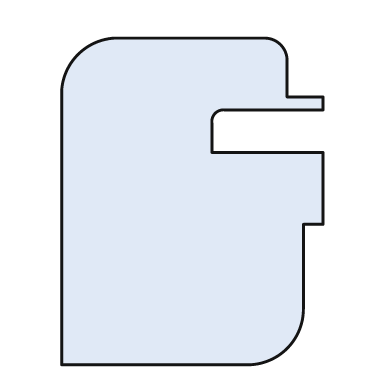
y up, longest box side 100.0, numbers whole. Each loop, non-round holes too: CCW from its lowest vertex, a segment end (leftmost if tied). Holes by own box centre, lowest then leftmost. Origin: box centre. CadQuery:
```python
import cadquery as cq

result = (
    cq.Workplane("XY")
    .moveTo(-40.0, -50.0)
    .lineTo(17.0, -50.0)
    .threePointArc((29.0, -45.0), (34.0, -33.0))
    .lineTo(34.0, -7.0)
    .lineTo(40.0, -7.0)
    .lineTo(40.0, 15.0)
    .lineTo(6.0, 15.0)
    .lineTo(6.0, 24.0)
    .threePointArc((7.0, 27.0), (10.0, 28.0))
    .lineTo(40.0, 28.0)
    .lineTo(40.0, 32.0)
    .lineTo(29.0, 32.0)
    .lineTo(29.0, 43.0)
    .threePointArc((27.0, 48.0), (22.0, 50.0))
    .lineTo(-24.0, 50.0)
    .threePointArc((-35.0, 45.0), (-40.0, 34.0))
    .close()
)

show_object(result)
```